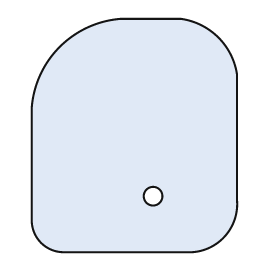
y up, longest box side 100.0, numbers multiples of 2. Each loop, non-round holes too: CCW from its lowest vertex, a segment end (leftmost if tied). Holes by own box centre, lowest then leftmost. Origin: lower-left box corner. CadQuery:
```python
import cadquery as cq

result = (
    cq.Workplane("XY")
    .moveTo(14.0, 0.0)
    .lineTo(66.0, 0.0)
    .threePointArc((82.0, 6.0), (88.0, 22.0))
    .lineTo(88.0, 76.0)
    .threePointArc((80.0, 92.0), (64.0, 100.0))
    .lineTo(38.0, 100.0)
    .threePointArc((12.0, 88.0), (0.0, 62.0))
    .lineTo(0.0, 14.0)
    .threePointArc((4.0, 4.0), (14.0, 0.0))
    .close()
    .moveTo(52.0, 24.0)
    .circle(4.0)
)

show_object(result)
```